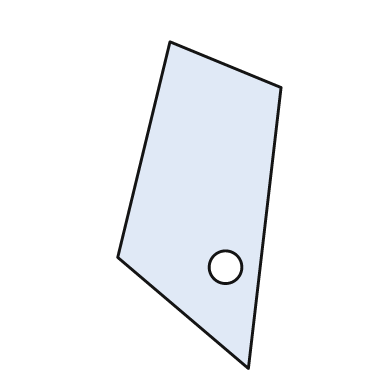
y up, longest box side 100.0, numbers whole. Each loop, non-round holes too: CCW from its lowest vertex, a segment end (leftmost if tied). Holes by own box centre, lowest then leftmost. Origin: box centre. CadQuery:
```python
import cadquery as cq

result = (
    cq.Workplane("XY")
    .moveTo(15.0, -50.0)
    .lineTo(25.0, 36.0)
    .lineTo(-9.0, 50.0)
    .lineTo(-25.0, -16.0)
    .close()
    .moveTo(8.0, -19.0)
    .circle(5.0)
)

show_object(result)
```